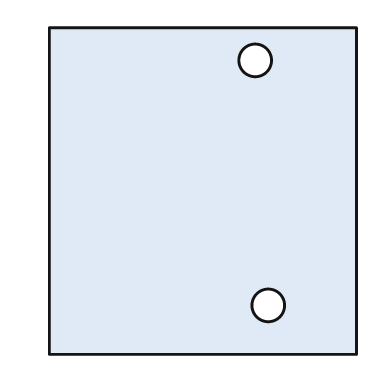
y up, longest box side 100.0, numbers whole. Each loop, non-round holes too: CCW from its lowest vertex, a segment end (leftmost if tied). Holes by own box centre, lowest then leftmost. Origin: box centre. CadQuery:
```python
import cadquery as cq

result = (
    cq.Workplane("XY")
    .moveTo(-47.0, -50.0)
    .lineTo(47.0, -50.0)
    .lineTo(47.0, 50.0)
    .lineTo(-47.0, 50.0)
    .close()
    .moveTo(20.0, -35.0)
    .circle(5.0)
    .moveTo(16.0, 40.0)
    .circle(5.0)
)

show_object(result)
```